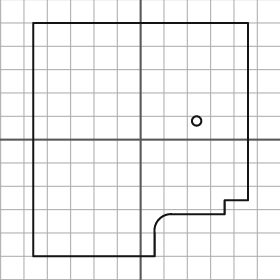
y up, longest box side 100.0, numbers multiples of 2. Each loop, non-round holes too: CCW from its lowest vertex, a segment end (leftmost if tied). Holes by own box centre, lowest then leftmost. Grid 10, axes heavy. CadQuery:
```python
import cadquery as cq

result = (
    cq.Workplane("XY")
    .moveTo(-46.0, -50.0)
    .lineTo(6.0, -50.0)
    .lineTo(6.0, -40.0)
    .threePointArc((8.0, -34.0), (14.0, -32.0))
    .lineTo(36.0, -32.0)
    .lineTo(36.0, -26.0)
    .lineTo(46.0, -26.0)
    .lineTo(46.0, 50.0)
    .lineTo(-46.0, 50.0)
    .close()
    .moveTo(24.0, 8.0)
    .circle(2.0)
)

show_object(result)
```